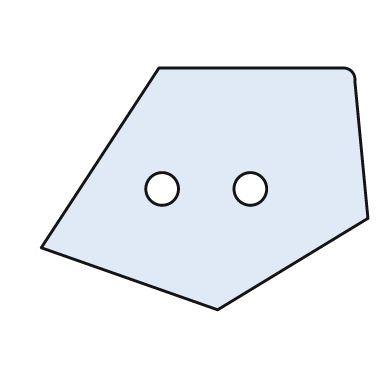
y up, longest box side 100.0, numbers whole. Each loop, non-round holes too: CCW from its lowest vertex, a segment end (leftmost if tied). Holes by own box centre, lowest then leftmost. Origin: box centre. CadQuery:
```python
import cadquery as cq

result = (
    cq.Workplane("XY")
    .moveTo(4.0, -37.0)
    .lineTo(50.0, -9.0)
    .lineTo(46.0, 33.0)
    .threePointArc((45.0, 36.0), (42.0, 37.0))
    .lineTo(-14.0, 37.0)
    .lineTo(-50.0, -18.0)
    .close()
    .moveTo(-13.0, 0.0)
    .circle(5.0)
    .moveTo(14.0, 0.0)
    .circle(5.0)
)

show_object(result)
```